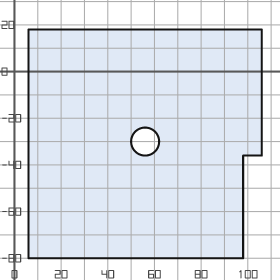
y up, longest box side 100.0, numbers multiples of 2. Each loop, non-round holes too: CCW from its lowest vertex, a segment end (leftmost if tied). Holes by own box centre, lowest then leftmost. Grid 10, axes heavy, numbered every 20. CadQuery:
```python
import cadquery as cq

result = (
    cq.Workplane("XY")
    .moveTo(6.0, -80.0)
    .lineTo(98.0, -80.0)
    .lineTo(98.0, -36.0)
    .lineTo(106.0, -36.0)
    .lineTo(106.0, 18.0)
    .lineTo(6.0, 18.0)
    .close()
    .moveTo(56.0, -30.0)
    .circle(6.0)
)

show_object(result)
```